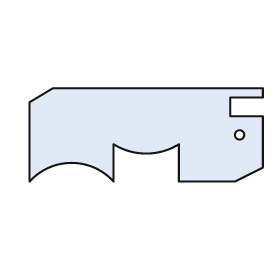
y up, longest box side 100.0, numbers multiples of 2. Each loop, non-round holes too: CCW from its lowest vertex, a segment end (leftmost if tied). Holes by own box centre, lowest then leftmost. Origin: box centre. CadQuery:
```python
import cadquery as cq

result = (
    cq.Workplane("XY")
    .moveTo(-50.0, -20.0)
    .threePointArc((-32.0, -12.0), (-14.0, -20.0))
    .lineTo(-14.0, -4.0)
    .threePointArc((0.0, -8.0), (14.0, -4.0))
    .lineTo(14.0, -20.0)
    .lineTo(38.0, -20.0)
    .lineTo(50.0, -14.0)
    .lineTo(50.0, 8.0)
    .lineTo(36.0, 8.0)
    .lineTo(36.0, 16.0)
    .lineTo(50.0, 16.0)
    .lineTo(50.0, 20.0)
    .lineTo(-40.0, 20.0)
    .lineTo(-50.0, 14.0)
    .close()
    .moveTo(40.0, 0.0)
    .circle(2.0)
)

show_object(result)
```